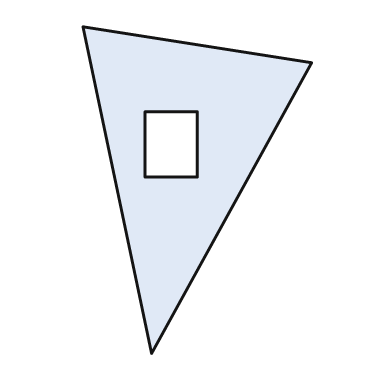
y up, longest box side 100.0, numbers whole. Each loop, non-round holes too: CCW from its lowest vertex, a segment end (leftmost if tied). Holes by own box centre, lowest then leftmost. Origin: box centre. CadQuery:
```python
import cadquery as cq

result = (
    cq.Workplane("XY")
    .moveTo(-14.0, -50.0)
    .lineTo(35.0, 39.0)
    .lineTo(-35.0, 50.0)
    .close()
    .moveTo(-16.0, 4.0)
    .lineTo(0.0, 4.0)
    .lineTo(0.0, 24.0)
    .lineTo(-16.0, 24.0)
    .close()
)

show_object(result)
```